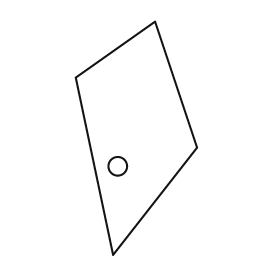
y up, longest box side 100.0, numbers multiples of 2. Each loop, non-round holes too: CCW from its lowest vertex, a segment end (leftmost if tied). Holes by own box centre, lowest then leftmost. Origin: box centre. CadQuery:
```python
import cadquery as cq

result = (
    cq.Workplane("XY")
    .moveTo(-10.0, -50.0)
    .lineTo(26.0, -4.0)
    .lineTo(8.0, 50.0)
    .lineTo(-26.0, 26.0)
    .close()
    .moveTo(-8.0, -12.0)
    .circle(4.0)
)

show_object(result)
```